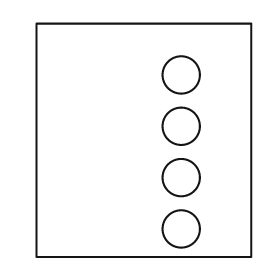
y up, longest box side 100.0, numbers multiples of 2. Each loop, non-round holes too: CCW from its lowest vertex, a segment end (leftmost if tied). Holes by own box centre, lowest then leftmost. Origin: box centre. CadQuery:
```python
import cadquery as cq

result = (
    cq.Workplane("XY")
    .moveTo(-46.0, -50.0)
    .lineTo(46.0, -50.0)
    .lineTo(46.0, 50.0)
    .lineTo(-46.0, 50.0)
    .close()
    .moveTo(16.0, -38.0)
    .circle(8.0)
    .moveTo(16.0, -16.0)
    .circle(8.0)
    .moveTo(16.0, 6.0)
    .circle(8.0)
    .moveTo(16.0, 28.0)
    .circle(8.0)
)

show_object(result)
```